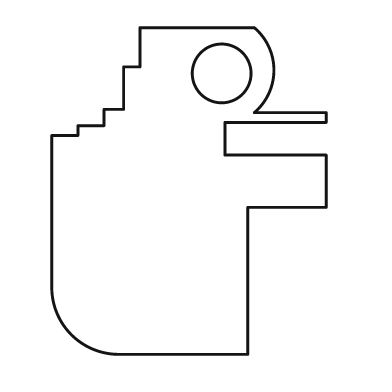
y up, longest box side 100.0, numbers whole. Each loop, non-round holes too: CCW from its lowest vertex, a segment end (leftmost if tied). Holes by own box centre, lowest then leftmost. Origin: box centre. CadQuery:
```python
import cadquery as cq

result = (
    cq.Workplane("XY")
    .moveTo(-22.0, -50.0)
    .lineTo(18.0, -50.0)
    .lineTo(18.0, -5.0)
    .lineTo(42.0, -5.0)
    .lineTo(42.0, 11.0)
    .lineTo(11.0, 11.0)
    .lineTo(11.0, 21.0)
    .lineTo(42.0, 21.0)
    .lineTo(42.0, 24.0)
    .lineTo(20.0, 24.0)
    .threePointArc((26.0, 37.0), (20.0, 50.0))
    .lineTo(-15.0, 50.0)
    .lineTo(-15.0, 38.0)
    .lineTo(-20.0, 38.0)
    .lineTo(-20.0, 25.0)
    .lineTo(-26.0, 25.0)
    .lineTo(-26.0, 20.0)
    .lineTo(-34.0, 20.0)
    .lineTo(-34.0, 17.0)
    .lineTo(-42.0, 17.0)
    .lineTo(-42.0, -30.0)
    .threePointArc((-36.0, -44.0), (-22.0, -50.0))
    .close()
    .moveTo(10.0, 36.0)
    .circle(9.0)
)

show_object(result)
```